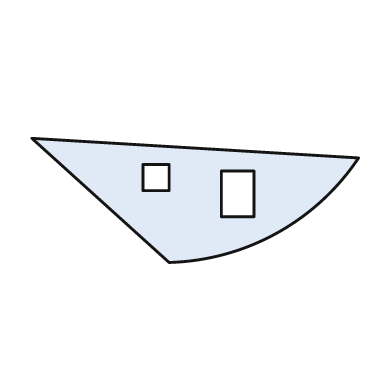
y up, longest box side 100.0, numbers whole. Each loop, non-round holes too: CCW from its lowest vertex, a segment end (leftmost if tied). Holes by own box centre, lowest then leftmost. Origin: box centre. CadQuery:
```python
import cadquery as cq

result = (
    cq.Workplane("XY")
    .moveTo(-8.0, -19.0)
    .threePointArc((25.0, -10.0), (50.0, 13.0))
    .lineTo(-50.0, 19.0)
    .close()
    .moveTo(8.0, -5.0)
    .lineTo(18.0, -5.0)
    .lineTo(18.0, 9.0)
    .lineTo(8.0, 9.0)
    .close()
    .moveTo(-16.0, 3.0)
    .lineTo(-8.0, 3.0)
    .lineTo(-8.0, 11.0)
    .lineTo(-16.0, 11.0)
    .close()
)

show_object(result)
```